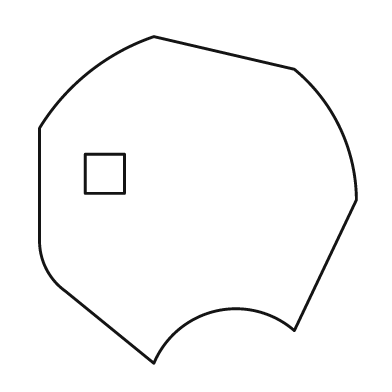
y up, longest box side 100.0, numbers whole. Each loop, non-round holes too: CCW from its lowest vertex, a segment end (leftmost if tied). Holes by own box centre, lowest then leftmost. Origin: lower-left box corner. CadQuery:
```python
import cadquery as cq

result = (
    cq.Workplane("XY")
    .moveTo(35.0, 0.0)
    .threePointArc((54.0, 16.0), (78.0, 10.0))
    .lineTo(97.0, 50.0)
    .threePointArc((92.0, 72.0), (78.0, 90.0))
    .lineTo(35.0, 100.0)
    .threePointArc((15.0, 89.0), (0.0, 72.0))
    .lineTo(0.0, 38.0)
    .threePointArc((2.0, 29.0), (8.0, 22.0))
    .close()
    .moveTo(14.0, 52.0)
    .lineTo(26.0, 52.0)
    .lineTo(26.0, 64.0)
    .lineTo(14.0, 64.0)
    .close()
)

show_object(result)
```